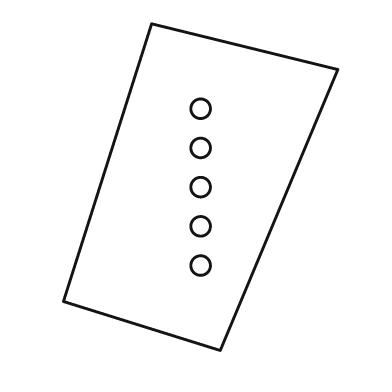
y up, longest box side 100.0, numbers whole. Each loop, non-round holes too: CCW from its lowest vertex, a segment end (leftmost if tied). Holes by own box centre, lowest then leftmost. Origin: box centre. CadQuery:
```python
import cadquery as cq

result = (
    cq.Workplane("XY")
    .moveTo(6.0, -50.0)
    .lineTo(42.0, 36.0)
    .lineTo(-15.0, 50.0)
    .lineTo(-42.0, -35.0)
    .close()
    .moveTo(0.0, -24.0)
    .circle(3.0)
    .moveTo(0.0, -12.0)
    .circle(3.0)
    .moveTo(0.0, 0.0)
    .circle(3.0)
    .moveTo(0.0, 12.0)
    .circle(3.0)
    .moveTo(0.0, 24.0)
    .circle(3.0)
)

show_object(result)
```